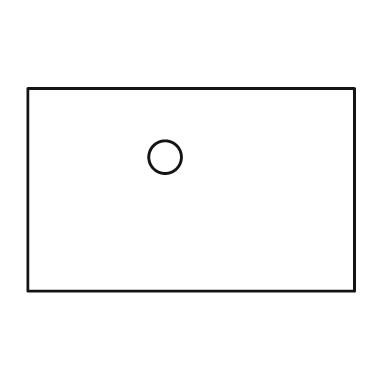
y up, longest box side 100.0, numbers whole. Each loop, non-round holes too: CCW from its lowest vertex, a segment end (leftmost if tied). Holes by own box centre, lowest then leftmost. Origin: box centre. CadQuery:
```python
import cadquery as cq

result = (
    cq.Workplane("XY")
    .moveTo(-50.0, -31.0)
    .lineTo(50.0, -31.0)
    .lineTo(50.0, 31.0)
    .lineTo(-50.0, 31.0)
    .close()
    .moveTo(-8.0, 10.0)
    .circle(5.0)
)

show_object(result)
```